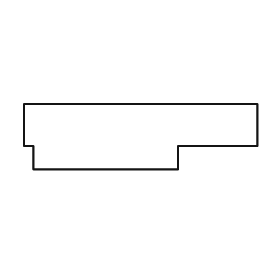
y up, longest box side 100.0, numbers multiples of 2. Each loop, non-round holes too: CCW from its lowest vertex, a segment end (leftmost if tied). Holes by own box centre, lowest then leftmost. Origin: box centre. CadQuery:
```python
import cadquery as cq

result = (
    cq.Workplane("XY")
    .moveTo(-46.0, -14.0)
    .lineTo(16.0, -14.0)
    .lineTo(16.0, -4.0)
    .lineTo(50.0, -4.0)
    .lineTo(50.0, 14.0)
    .lineTo(-50.0, 14.0)
    .lineTo(-50.0, -4.0)
    .lineTo(-46.0, -4.0)
    .close()
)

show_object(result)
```